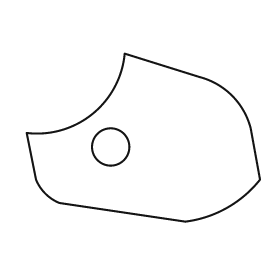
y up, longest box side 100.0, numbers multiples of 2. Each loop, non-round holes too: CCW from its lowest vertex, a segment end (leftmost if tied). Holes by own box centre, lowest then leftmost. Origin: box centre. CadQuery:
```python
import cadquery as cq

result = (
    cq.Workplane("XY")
    .moveTo(18.0, -36.0)
    .threePointArc((36.0, -30.0), (50.0, -18.0))
    .lineTo(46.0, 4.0)
    .threePointArc((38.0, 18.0), (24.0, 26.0))
    .lineTo(-8.0, 36.0)
    .threePointArc((-22.0, 10.0), (-50.0, 2.0))
    .lineTo(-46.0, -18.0)
    .threePointArc((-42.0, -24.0), (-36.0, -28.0))
    .close()
    .moveTo(-14.0, -4.0)
    .circle(8.0)
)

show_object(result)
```